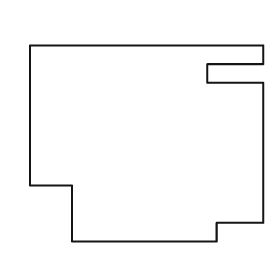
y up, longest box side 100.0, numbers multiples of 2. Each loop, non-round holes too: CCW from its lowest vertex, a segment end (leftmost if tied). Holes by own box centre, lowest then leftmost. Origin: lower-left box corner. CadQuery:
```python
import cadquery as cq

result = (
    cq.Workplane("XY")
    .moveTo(18.0, 0.0)
    .lineTo(80.0, 0.0)
    .lineTo(80.0, 8.0)
    .lineTo(100.0, 8.0)
    .lineTo(100.0, 68.0)
    .lineTo(76.0, 68.0)
    .lineTo(76.0, 76.0)
    .lineTo(100.0, 76.0)
    .lineTo(100.0, 84.0)
    .lineTo(0.0, 84.0)
    .lineTo(0.0, 24.0)
    .lineTo(18.0, 24.0)
    .close()
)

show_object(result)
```